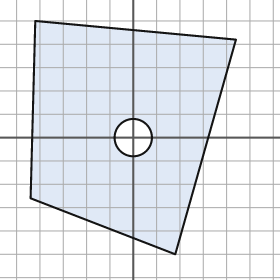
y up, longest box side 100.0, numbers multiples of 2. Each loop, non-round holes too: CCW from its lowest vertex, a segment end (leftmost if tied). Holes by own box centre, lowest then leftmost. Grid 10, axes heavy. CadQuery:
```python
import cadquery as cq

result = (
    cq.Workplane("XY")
    .moveTo(18.0, -50.0)
    .lineTo(44.0, 42.0)
    .lineTo(-42.0, 50.0)
    .lineTo(-44.0, -26.0)
    .close()
    .moveTo(0.0, 0.0)
    .circle(8.0)
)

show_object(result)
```